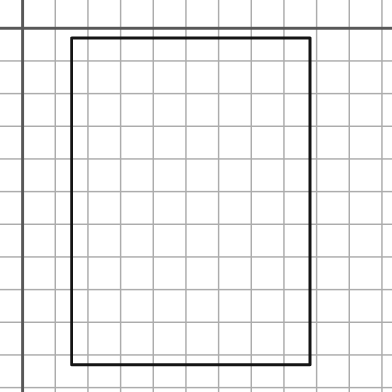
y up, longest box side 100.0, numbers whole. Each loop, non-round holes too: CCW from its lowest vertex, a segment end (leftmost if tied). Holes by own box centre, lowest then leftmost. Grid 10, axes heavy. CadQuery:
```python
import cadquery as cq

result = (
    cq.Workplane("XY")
    .moveTo(15.0, -103.0)
    .lineTo(88.0, -103.0)
    .lineTo(88.0, -3.0)
    .lineTo(15.0, -3.0)
    .close()
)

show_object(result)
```